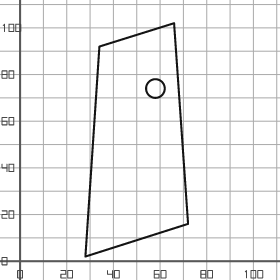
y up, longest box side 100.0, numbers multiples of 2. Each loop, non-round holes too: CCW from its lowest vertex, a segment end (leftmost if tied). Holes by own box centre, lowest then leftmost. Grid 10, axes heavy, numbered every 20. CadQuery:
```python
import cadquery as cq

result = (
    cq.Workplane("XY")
    .moveTo(28.0, 2.0)
    .lineTo(72.0, 16.0)
    .lineTo(66.0, 102.0)
    .lineTo(34.0, 92.0)
    .close()
    .moveTo(58.0, 74.0)
    .circle(4.0)
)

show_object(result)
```